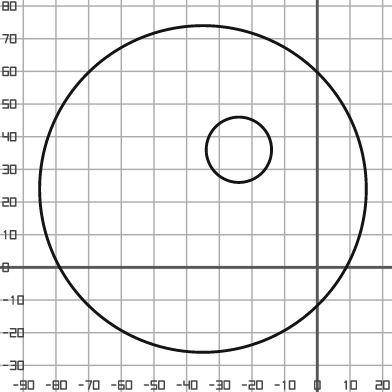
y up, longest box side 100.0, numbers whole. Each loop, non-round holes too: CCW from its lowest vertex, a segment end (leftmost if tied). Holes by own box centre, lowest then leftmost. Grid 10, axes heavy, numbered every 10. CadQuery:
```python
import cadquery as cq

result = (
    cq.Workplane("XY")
    .moveTo(-35.0, 24.0)
    .circle(50.0)
    .moveTo(-24.0, 36.0)
    .circle(10.0)
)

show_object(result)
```